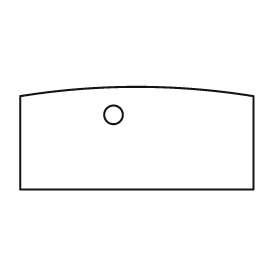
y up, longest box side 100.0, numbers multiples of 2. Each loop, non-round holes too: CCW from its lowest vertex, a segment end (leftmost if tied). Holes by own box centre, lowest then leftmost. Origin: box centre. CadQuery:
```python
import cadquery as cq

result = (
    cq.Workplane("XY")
    .moveTo(-50.0, -22.0)
    .lineTo(50.0, -22.0)
    .lineTo(50.0, 18.0)
    .threePointArc((0.0, 22.0), (-50.0, 18.0))
    .close()
    .moveTo(-10.0, 10.0)
    .circle(4.0)
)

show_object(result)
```